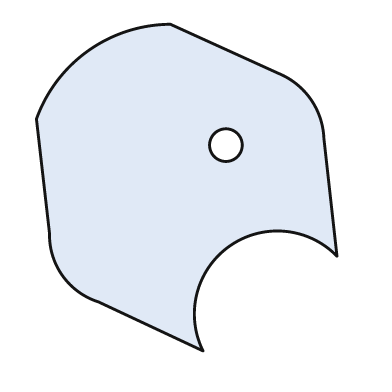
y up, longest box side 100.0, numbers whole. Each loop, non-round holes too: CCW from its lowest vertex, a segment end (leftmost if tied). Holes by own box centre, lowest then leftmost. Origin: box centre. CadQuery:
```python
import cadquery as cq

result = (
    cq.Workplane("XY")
    .moveTo(5.0, -50.0)
    .threePointArc((13.0, -18.0), (46.0, -21.0))
    .lineTo(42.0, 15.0)
    .threePointArc((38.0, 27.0), (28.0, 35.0))
    .lineTo(-5.0, 50.0)
    .threePointArc((-30.0, 42.0), (-46.0, 21.0))
    .lineTo(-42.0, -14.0)
    .threePointArc((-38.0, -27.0), (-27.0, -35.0))
    .close()
    .moveTo(12.0, 13.0)
    .circle(5.0)
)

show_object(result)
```